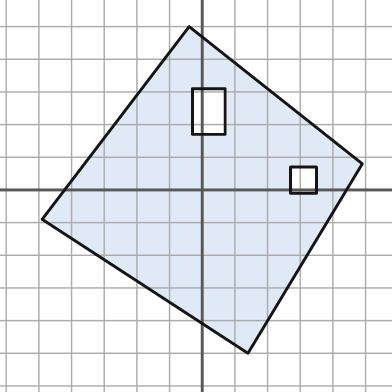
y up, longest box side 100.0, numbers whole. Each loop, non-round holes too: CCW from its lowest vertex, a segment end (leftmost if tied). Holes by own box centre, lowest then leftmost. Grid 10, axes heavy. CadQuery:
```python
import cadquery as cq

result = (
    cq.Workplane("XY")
    .moveTo(14.0, -50.0)
    .lineTo(49.0, 8.0)
    .lineTo(-4.0, 50.0)
    .lineTo(-49.0, -9.0)
    .close()
    .moveTo(27.0, -1.0)
    .lineTo(35.0, -1.0)
    .lineTo(35.0, 7.0)
    .lineTo(27.0, 7.0)
    .close()
    .moveTo(-3.0, 17.0)
    .lineTo(7.0, 17.0)
    .lineTo(7.0, 31.0)
    .lineTo(-3.0, 31.0)
    .close()
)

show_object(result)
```